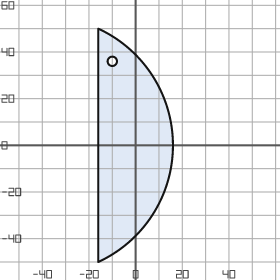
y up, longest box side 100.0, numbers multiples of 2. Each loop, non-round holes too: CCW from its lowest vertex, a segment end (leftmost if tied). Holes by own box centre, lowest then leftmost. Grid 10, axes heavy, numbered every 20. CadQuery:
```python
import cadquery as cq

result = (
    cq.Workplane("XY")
    .moveTo(-16.0, -50.0)
    .threePointArc((16.0, 0.0), (-16.0, 50.0))
    .close()
    .moveTo(-10.0, 36.0)
    .circle(2.0)
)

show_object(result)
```